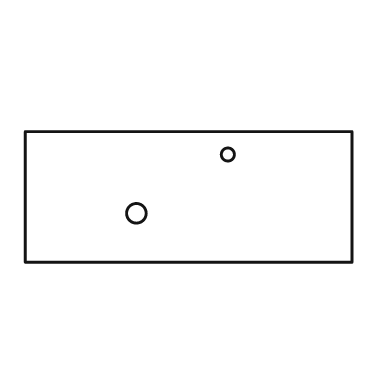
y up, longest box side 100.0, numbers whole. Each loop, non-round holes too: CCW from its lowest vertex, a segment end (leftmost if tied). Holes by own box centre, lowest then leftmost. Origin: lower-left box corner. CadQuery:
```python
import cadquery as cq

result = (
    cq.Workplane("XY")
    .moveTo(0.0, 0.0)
    .lineTo(100.0, 0.0)
    .lineTo(100.0, 40.0)
    .lineTo(0.0, 40.0)
    .close()
    .moveTo(34.0, 15.0)
    .circle(3.0)
    .moveTo(62.0, 33.0)
    .circle(2.0)
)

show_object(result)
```